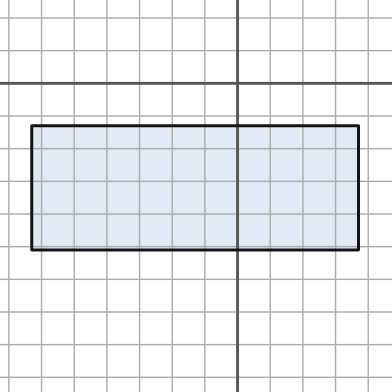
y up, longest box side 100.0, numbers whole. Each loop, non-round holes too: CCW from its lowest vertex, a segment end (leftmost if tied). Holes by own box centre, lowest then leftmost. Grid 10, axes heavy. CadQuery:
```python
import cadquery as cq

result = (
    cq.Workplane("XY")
    .moveTo(-63.0, -51.0)
    .lineTo(37.0, -51.0)
    .lineTo(37.0, -13.0)
    .lineTo(-63.0, -13.0)
    .close()
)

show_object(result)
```